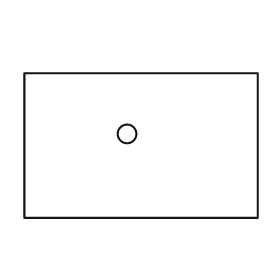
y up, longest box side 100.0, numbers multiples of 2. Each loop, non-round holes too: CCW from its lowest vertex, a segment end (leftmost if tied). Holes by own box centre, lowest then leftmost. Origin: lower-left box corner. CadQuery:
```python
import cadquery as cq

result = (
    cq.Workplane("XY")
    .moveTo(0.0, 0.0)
    .lineTo(100.0, 0.0)
    .lineTo(100.0, 62.0)
    .lineTo(0.0, 62.0)
    .close()
    .moveTo(44.0, 36.0)
    .circle(4.0)
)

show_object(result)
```